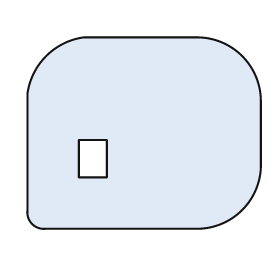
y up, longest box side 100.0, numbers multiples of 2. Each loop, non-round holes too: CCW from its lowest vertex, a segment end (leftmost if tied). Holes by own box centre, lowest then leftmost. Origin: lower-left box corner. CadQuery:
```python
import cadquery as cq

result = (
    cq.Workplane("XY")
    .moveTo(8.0, 0.0)
    .lineTo(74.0, 0.0)
    .threePointArc((92.0, 8.0), (100.0, 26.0))
    .lineTo(100.0, 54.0)
    .threePointArc((92.0, 74.0), (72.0, 82.0))
    .lineTo(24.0, 82.0)
    .threePointArc((8.0, 74.0), (0.0, 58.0))
    .lineTo(0.0, 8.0)
    .threePointArc((2.0, 2.0), (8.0, 0.0))
    .close()
    .moveTo(22.0, 22.0)
    .lineTo(34.0, 22.0)
    .lineTo(34.0, 38.0)
    .lineTo(22.0, 38.0)
    .close()
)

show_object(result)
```